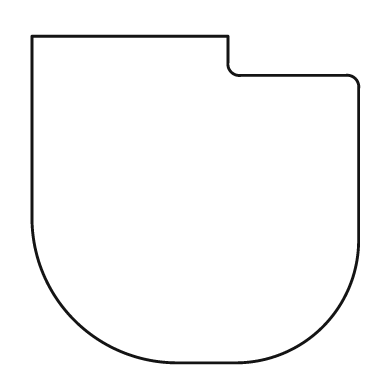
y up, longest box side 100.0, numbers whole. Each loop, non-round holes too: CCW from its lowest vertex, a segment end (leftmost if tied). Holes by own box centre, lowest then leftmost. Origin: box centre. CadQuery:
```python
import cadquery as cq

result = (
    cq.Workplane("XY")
    .moveTo(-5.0, -50.0)
    .lineTo(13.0, -50.0)
    .threePointArc((39.0, -39.0), (50.0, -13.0))
    .lineTo(50.0, 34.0)
    .threePointArc((49.0, 37.0), (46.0, 38.0))
    .lineTo(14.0, 38.0)
    .threePointArc((11.0, 39.0), (10.0, 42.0))
    .lineTo(10.0, 50.0)
    .lineTo(-50.0, 50.0)
    .lineTo(-50.0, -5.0)
    .threePointArc((-37.0, -37.0), (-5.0, -50.0))
    .close()
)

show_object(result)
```